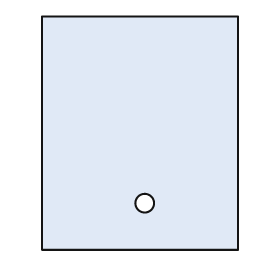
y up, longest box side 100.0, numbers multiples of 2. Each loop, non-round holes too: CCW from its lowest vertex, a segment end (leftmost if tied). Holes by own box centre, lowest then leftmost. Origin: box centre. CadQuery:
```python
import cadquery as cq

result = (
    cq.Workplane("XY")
    .moveTo(-42.0, -50.0)
    .lineTo(42.0, -50.0)
    .lineTo(42.0, 50.0)
    .lineTo(-42.0, 50.0)
    .close()
    .moveTo(2.0, -30.0)
    .circle(4.0)
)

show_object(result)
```